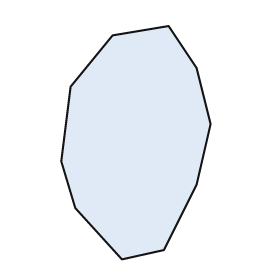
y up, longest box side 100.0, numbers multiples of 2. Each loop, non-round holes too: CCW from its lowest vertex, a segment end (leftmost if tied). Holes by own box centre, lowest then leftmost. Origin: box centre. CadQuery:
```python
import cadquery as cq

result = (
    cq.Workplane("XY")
    .moveTo(-6.0, -50.0)
    .lineTo(12.0, -46.0)
    .lineTo(26.0, -18.0)
    .lineTo(32.0, 8.0)
    .lineTo(26.0, 32.0)
    .lineTo(14.0, 50.0)
    .lineTo(-10.0, 46.0)
    .lineTo(-28.0, 24.0)
    .lineTo(-32.0, -8.0)
    .lineTo(-26.0, -28.0)
    .close()
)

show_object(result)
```